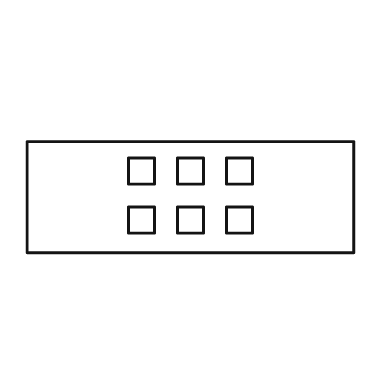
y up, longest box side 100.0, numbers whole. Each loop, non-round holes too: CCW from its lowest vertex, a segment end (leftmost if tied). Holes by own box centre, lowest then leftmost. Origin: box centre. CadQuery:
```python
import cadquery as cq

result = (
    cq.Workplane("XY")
    .moveTo(-50.0, -17.0)
    .lineTo(50.0, -17.0)
    .lineTo(50.0, 17.0)
    .lineTo(-50.0, 17.0)
    .close()
    .moveTo(-19.0, -11.0)
    .lineTo(-11.0, -11.0)
    .lineTo(-11.0, -3.0)
    .lineTo(-19.0, -3.0)
    .close()
    .moveTo(-4.0, -11.0)
    .lineTo(4.0, -11.0)
    .lineTo(4.0, -3.0)
    .lineTo(-4.0, -3.0)
    .close()
    .moveTo(11.0, -11.0)
    .lineTo(19.0, -11.0)
    .lineTo(19.0, -3.0)
    .lineTo(11.0, -3.0)
    .close()
    .moveTo(-19.0, 4.0)
    .lineTo(-11.0, 4.0)
    .lineTo(-11.0, 12.0)
    .lineTo(-19.0, 12.0)
    .close()
    .moveTo(-4.0, 4.0)
    .lineTo(4.0, 4.0)
    .lineTo(4.0, 12.0)
    .lineTo(-4.0, 12.0)
    .close()
    .moveTo(11.0, 4.0)
    .lineTo(19.0, 4.0)
    .lineTo(19.0, 12.0)
    .lineTo(11.0, 12.0)
    .close()
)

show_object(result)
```